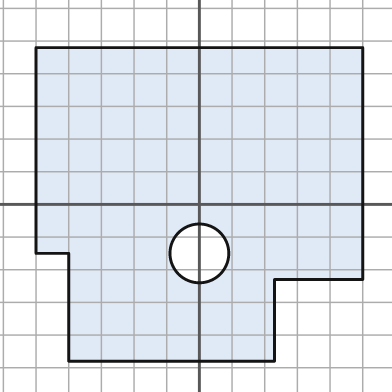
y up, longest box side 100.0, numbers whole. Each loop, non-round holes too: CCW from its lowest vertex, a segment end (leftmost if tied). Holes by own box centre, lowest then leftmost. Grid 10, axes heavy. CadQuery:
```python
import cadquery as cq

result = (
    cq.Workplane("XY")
    .moveTo(-40.0, -48.0)
    .lineTo(23.0, -48.0)
    .lineTo(23.0, -23.0)
    .lineTo(50.0, -23.0)
    .lineTo(50.0, 48.0)
    .lineTo(-50.0, 48.0)
    .lineTo(-50.0, -15.0)
    .lineTo(-40.0, -15.0)
    .close()
    .moveTo(0.0, -15.0)
    .circle(9.0)
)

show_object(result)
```